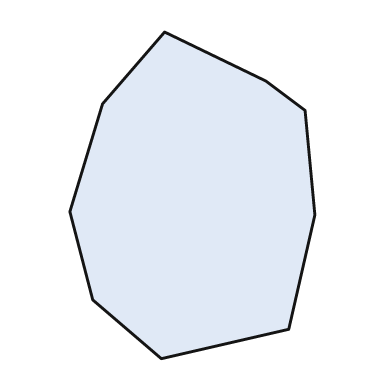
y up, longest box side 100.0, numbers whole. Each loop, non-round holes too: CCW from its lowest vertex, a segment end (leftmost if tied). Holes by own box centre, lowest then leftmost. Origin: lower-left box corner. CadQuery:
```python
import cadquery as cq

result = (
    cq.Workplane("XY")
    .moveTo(28.0, 0.0)
    .lineTo(67.0, 9.0)
    .lineTo(75.0, 44.0)
    .lineTo(72.0, 76.0)
    .lineTo(60.0, 85.0)
    .lineTo(29.0, 100.0)
    .lineTo(10.0, 78.0)
    .lineTo(0.0, 45.0)
    .lineTo(7.0, 18.0)
    .close()
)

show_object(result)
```